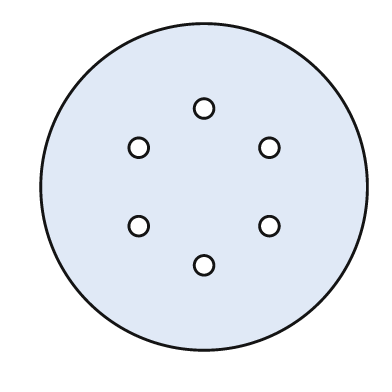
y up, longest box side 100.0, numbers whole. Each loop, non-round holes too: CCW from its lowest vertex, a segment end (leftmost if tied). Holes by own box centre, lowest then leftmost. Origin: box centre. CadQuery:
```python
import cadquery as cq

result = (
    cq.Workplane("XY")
    .moveTo(0.0, 0.0)
    .circle(50.0)
    .moveTo(0.0, -24.0)
    .circle(3.0)
    .moveTo(-20.0, -12.0)
    .circle(3.0)
    .moveTo(20.0, -12.0)
    .circle(3.0)
    .moveTo(-20.0, 12.0)
    .circle(3.0)
    .moveTo(20.0, 12.0)
    .circle(3.0)
    .moveTo(0.0, 24.0)
    .circle(3.0)
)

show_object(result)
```